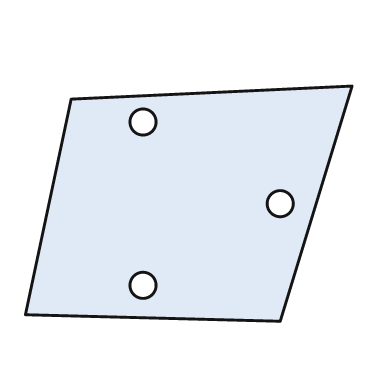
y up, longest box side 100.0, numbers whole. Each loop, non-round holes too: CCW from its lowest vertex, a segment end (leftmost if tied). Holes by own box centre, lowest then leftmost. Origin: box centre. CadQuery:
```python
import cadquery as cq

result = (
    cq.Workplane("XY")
    .moveTo(28.0, -36.0)
    .lineTo(50.0, 36.0)
    .lineTo(-36.0, 32.0)
    .lineTo(-50.0, -34.0)
    .close()
    .moveTo(-14.0, -25.0)
    .circle(4.0)
    .moveTo(28.0, 0.0)
    .circle(4.0)
    .moveTo(-14.0, 25.0)
    .circle(4.0)
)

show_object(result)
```